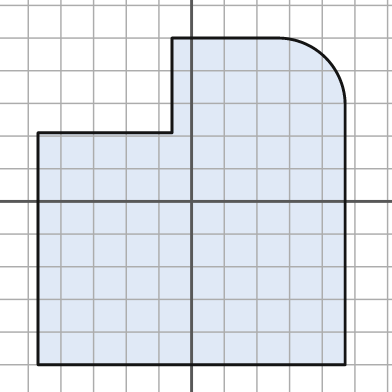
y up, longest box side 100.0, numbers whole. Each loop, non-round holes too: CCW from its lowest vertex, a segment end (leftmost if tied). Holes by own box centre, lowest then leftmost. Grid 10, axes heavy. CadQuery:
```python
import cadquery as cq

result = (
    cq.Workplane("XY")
    .moveTo(-47.0, -50.0)
    .lineTo(47.0, -50.0)
    .lineTo(47.0, 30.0)
    .threePointArc((41.0, 44.0), (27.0, 50.0))
    .lineTo(-6.0, 50.0)
    .lineTo(-6.0, 21.0)
    .lineTo(-47.0, 21.0)
    .close()
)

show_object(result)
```